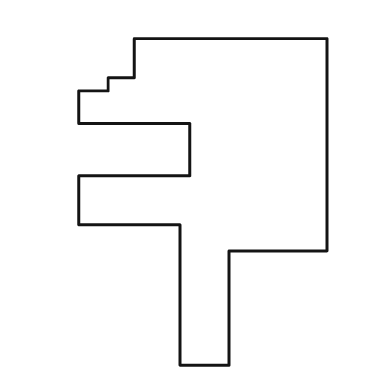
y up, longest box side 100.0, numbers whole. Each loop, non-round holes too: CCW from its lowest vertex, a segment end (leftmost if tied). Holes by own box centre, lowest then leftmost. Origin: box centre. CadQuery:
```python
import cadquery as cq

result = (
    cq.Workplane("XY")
    .moveTo(-7.0, -50.0)
    .lineTo(8.0, -50.0)
    .lineTo(8.0, -15.0)
    .lineTo(38.0, -15.0)
    .lineTo(38.0, 50.0)
    .lineTo(-21.0, 50.0)
    .lineTo(-21.0, 38.0)
    .lineTo(-29.0, 38.0)
    .lineTo(-29.0, 34.0)
    .lineTo(-38.0, 34.0)
    .lineTo(-38.0, 24.0)
    .lineTo(-4.0, 24.0)
    .lineTo(-4.0, 8.0)
    .lineTo(-38.0, 8.0)
    .lineTo(-38.0, -7.0)
    .lineTo(-7.0, -7.0)
    .close()
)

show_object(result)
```